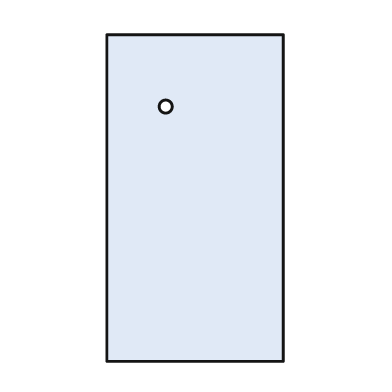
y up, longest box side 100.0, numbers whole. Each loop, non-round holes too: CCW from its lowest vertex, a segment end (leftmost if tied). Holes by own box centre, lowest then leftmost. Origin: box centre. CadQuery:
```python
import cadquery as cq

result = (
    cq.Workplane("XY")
    .moveTo(-27.0, -50.0)
    .lineTo(27.0, -50.0)
    .lineTo(27.0, 50.0)
    .lineTo(-27.0, 50.0)
    .close()
    .moveTo(-9.0, 28.0)
    .circle(2.0)
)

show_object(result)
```